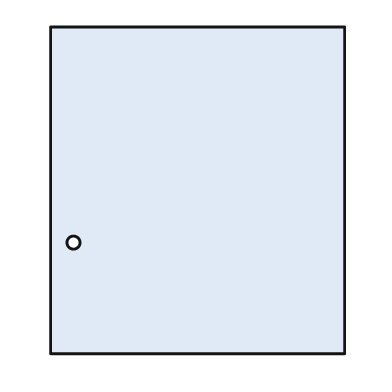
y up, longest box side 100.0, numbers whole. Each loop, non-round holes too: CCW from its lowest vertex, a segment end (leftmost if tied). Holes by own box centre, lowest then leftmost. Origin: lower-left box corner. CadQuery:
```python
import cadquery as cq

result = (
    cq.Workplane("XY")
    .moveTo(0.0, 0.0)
    .lineTo(90.0, 0.0)
    .lineTo(90.0, 100.0)
    .lineTo(0.0, 100.0)
    .close()
    .moveTo(7.0, 34.0)
    .circle(2.0)
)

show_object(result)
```